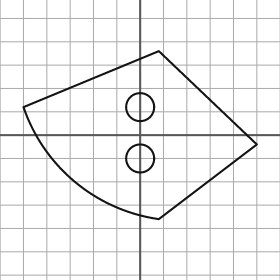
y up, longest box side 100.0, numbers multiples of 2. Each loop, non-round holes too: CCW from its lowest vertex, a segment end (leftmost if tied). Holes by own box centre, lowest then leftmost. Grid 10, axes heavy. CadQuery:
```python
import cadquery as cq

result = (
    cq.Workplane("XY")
    .moveTo(8.0, -36.0)
    .lineTo(50.0, -4.0)
    .lineTo(8.0, 36.0)
    .lineTo(-50.0, 12.0)
    .threePointArc((-28.0, -20.0), (8.0, -36.0))
    .close()
    .moveTo(0.0, -10.0)
    .circle(6.0)
    .moveTo(0.0, 12.0)
    .circle(6.0)
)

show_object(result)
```